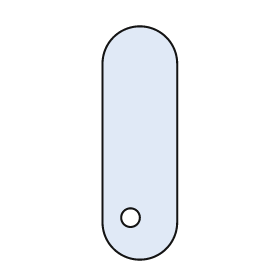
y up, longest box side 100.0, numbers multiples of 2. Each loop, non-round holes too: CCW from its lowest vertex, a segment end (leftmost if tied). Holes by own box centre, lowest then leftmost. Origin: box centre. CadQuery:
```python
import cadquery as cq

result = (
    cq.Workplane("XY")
    .moveTo(-16.0, -34.0)
    .threePointArc((0.0, -50.0), (16.0, -34.0))
    .lineTo(16.0, 34.0)
    .threePointArc((0.0, 50.0), (-16.0, 34.0))
    .close()
    .moveTo(-4.0, -32.0)
    .circle(4.0)
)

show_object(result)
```